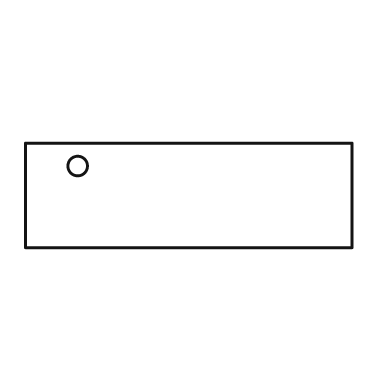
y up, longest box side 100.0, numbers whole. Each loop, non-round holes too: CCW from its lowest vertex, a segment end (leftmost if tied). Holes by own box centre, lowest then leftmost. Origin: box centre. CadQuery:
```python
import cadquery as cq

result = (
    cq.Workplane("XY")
    .moveTo(-50.0, -16.0)
    .lineTo(50.0, -16.0)
    .lineTo(50.0, 16.0)
    .lineTo(-50.0, 16.0)
    .close()
    .moveTo(-34.0, 9.0)
    .circle(3.0)
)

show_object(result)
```